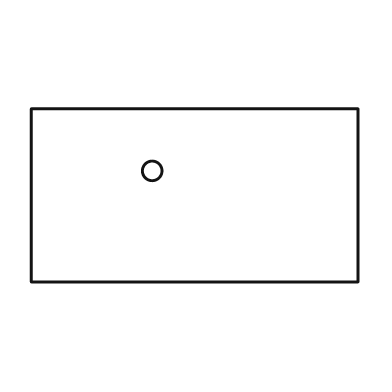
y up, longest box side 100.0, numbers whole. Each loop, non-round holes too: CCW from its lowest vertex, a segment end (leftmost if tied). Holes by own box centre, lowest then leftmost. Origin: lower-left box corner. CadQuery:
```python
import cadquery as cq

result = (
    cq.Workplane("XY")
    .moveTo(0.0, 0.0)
    .lineTo(100.0, 0.0)
    .lineTo(100.0, 53.0)
    .lineTo(0.0, 53.0)
    .close()
    .moveTo(37.0, 34.0)
    .circle(3.0)
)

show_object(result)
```